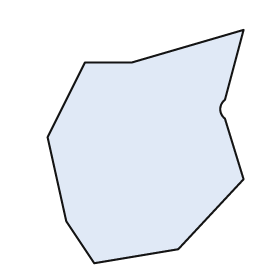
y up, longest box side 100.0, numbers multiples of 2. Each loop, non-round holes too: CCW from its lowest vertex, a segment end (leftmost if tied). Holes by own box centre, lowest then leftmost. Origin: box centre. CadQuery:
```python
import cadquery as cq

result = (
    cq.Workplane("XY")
    .moveTo(-22.0, -50.0)
    .lineTo(14.0, -44.0)
    .lineTo(42.0, -14.0)
    .lineTo(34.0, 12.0)
    .threePointArc((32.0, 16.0), (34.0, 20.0))
    .lineTo(42.0, 50.0)
    .lineTo(-6.0, 36.0)
    .lineTo(-26.0, 36.0)
    .lineTo(-42.0, 4.0)
    .lineTo(-34.0, -32.0)
    .close()
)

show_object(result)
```